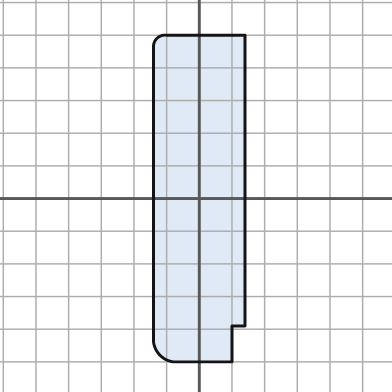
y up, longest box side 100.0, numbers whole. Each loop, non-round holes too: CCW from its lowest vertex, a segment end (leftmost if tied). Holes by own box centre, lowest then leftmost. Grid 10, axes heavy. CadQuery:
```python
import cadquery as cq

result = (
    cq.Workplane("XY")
    .moveTo(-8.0, -50.0)
    .lineTo(10.0, -50.0)
    .lineTo(10.0, -39.0)
    .lineTo(14.0, -39.0)
    .lineTo(14.0, 50.0)
    .lineTo(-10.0, 50.0)
    .threePointArc((-13.0, 49.0), (-14.0, 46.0))
    .lineTo(-14.0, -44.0)
    .threePointArc((-12.0, -48.0), (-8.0, -50.0))
    .close()
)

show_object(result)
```